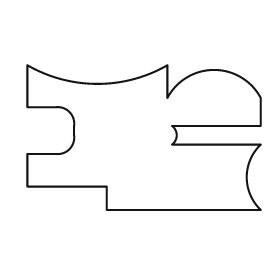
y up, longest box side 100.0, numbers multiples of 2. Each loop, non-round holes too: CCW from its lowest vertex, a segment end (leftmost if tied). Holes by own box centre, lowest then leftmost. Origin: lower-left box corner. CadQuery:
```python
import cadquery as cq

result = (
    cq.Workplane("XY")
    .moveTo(34.0, 0.0)
    .lineTo(100.0, 0.0)
    .threePointArc((94.0, 14.0), (100.0, 28.0))
    .lineTo(62.0, 28.0)
    .threePointArc((64.0, 32.0), (62.0, 36.0))
    .lineTo(100.0, 36.0)
    .lineTo(100.0, 48.0)
    .threePointArc((80.0, 60.0), (60.0, 48.0))
    .lineTo(60.0, 62.0)
    .threePointArc((30.0, 54.0), (0.0, 62.0))
    .lineTo(0.0, 44.0)
    .lineTo(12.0, 44.0)
    .threePointArc((18.0, 42.0), (20.0, 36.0))
    .lineTo(20.0, 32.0)
    .threePointArc((18.0, 26.0), (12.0, 24.0))
    .lineTo(0.0, 24.0)
    .lineTo(0.0, 10.0)
    .lineTo(34.0, 10.0)
    .close()
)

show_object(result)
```